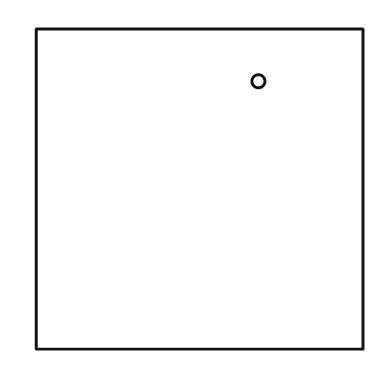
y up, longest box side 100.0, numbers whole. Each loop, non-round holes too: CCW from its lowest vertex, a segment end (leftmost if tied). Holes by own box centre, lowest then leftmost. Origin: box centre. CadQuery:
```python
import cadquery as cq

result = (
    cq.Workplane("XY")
    .moveTo(-50.0, -49.0)
    .lineTo(50.0, -49.0)
    .lineTo(50.0, 49.0)
    .lineTo(-50.0, 49.0)
    .close()
    .moveTo(18.0, 33.0)
    .circle(2.0)
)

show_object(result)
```